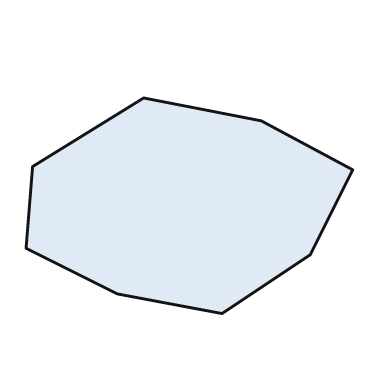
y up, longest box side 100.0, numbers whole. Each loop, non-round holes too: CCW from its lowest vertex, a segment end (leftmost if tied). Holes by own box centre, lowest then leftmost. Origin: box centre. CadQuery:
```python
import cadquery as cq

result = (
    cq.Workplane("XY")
    .moveTo(10.0, -33.0)
    .lineTo(37.0, -15.0)
    .lineTo(50.0, 11.0)
    .lineTo(22.0, 26.0)
    .lineTo(-14.0, 33.0)
    .lineTo(-48.0, 12.0)
    .lineTo(-50.0, -13.0)
    .lineTo(-22.0, -27.0)
    .close()
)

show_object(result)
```